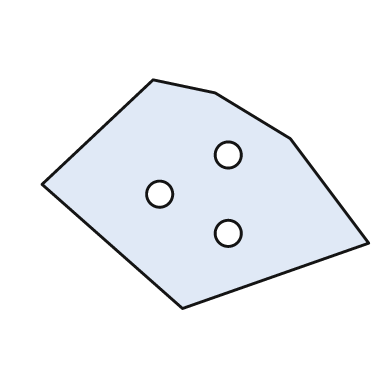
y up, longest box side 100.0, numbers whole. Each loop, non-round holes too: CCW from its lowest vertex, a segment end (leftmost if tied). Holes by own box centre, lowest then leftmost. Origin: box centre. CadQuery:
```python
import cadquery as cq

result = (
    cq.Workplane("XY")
    .moveTo(-7.0, -35.0)
    .lineTo(50.0, -15.0)
    .lineTo(26.0, 17.0)
    .lineTo(3.0, 31.0)
    .lineTo(-16.0, 35.0)
    .lineTo(-50.0, 3.0)
    .close()
    .moveTo(7.0, -12.0)
    .circle(4.0)
    .moveTo(-14.0, 0.0)
    .circle(4.0)
    .moveTo(7.0, 12.0)
    .circle(4.0)
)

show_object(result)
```